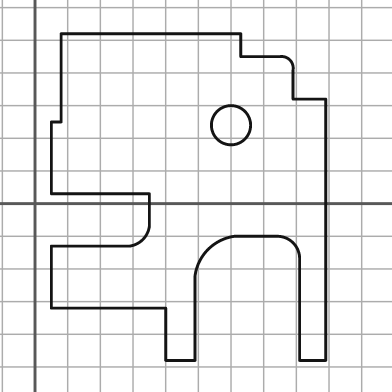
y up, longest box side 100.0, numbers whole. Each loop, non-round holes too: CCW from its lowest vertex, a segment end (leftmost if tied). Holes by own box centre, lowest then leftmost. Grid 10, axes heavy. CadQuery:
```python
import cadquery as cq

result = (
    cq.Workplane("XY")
    .moveTo(40.0, -48.0)
    .lineTo(49.0, -48.0)
    .lineTo(49.0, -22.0)
    .threePointArc((53.0, -14.0), (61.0, -10.0))
    .lineTo(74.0, -10.0)
    .threePointArc((79.0, -12.0), (81.0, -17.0))
    .lineTo(81.0, -48.0)
    .lineTo(89.0, -48.0)
    .lineTo(89.0, 32.0)
    .lineTo(79.0, 32.0)
    .lineTo(79.0, 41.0)
    .threePointArc((78.0, 44.0), (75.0, 45.0))
    .lineTo(63.0, 45.0)
    .lineTo(63.0, 52.0)
    .lineTo(8.0, 52.0)
    .lineTo(8.0, 25.0)
    .lineTo(5.0, 25.0)
    .lineTo(5.0, 3.0)
    .lineTo(35.0, 3.0)
    .lineTo(35.0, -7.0)
    .threePointArc((33.0, -11.0), (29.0, -13.0))
    .lineTo(5.0, -13.0)
    .lineTo(5.0, -32.0)
    .lineTo(40.0, -32.0)
    .close()
    .moveTo(60.0, 24.0)
    .circle(6.0)
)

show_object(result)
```